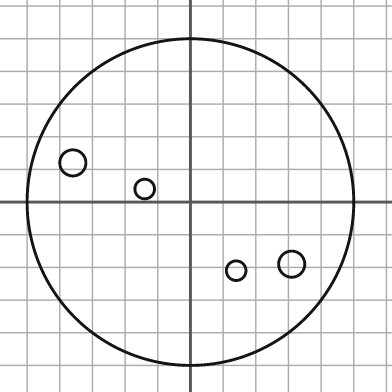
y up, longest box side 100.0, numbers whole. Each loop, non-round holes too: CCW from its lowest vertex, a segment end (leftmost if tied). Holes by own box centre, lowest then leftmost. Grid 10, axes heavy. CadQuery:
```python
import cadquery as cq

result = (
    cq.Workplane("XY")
    .moveTo(0.0, 0.0)
    .circle(50.0)
    .moveTo(14.0, -21.0)
    .circle(3.0)
    .moveTo(31.0, -19.0)
    .circle(4.0)
    .moveTo(-14.0, 4.0)
    .circle(3.0)
    .moveTo(-36.0, 12.0)
    .circle(4.0)
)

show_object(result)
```